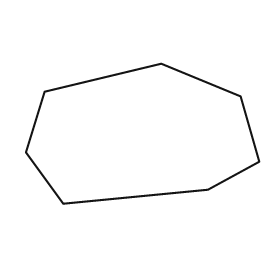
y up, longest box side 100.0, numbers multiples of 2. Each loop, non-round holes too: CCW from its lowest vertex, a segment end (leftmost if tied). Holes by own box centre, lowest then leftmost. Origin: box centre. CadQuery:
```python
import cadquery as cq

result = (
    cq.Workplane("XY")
    .moveTo(-34.0, -30.0)
    .lineTo(28.0, -24.0)
    .lineTo(50.0, -12.0)
    .lineTo(42.0, 16.0)
    .lineTo(8.0, 30.0)
    .lineTo(-42.0, 18.0)
    .lineTo(-50.0, -8.0)
    .close()
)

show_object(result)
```